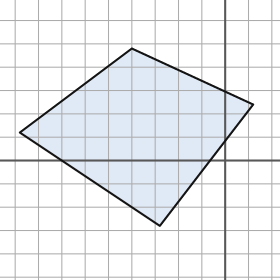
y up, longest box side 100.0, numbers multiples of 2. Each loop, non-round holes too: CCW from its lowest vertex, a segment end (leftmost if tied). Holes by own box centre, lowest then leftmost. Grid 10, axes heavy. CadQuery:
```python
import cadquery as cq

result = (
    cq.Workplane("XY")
    .moveTo(-28.0, -28.0)
    .lineTo(12.0, 24.0)
    .lineTo(-40.0, 48.0)
    .lineTo(-88.0, 12.0)
    .close()
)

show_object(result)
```